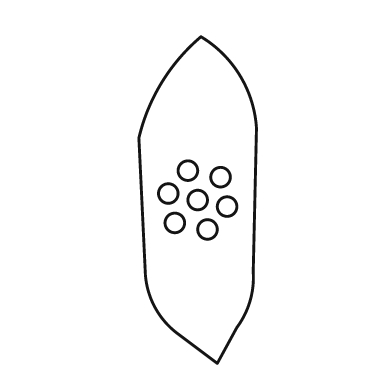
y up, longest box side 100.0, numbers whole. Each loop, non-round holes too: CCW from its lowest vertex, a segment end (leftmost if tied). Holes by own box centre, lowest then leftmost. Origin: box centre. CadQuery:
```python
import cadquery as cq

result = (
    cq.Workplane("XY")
    .moveTo(6.0, -50.0)
    .lineTo(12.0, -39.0)
    .threePointArc((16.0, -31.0), (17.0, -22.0))
    .lineTo(18.0, 22.0)
    .threePointArc((13.0, 38.0), (1.0, 50.0))
    .threePointArc((-11.0, 36.0), (-18.0, 19.0))
    .lineTo(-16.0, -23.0)
    .threePointArc((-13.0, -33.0), (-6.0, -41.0))
    .close()
    .moveTo(3.0, -9.0)
    .circle(3.0)
    .moveTo(-7.0, -7.0)
    .circle(3.0)
    .moveTo(9.0, -2.0)
    .circle(3.0)
    .moveTo(0.0, 0.0)
    .circle(3.0)
    .moveTo(-9.0, 2.0)
    .circle(3.0)
    .moveTo(7.0, 7.0)
    .circle(3.0)
    .moveTo(-3.0, 9.0)
    .circle(3.0)
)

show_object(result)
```